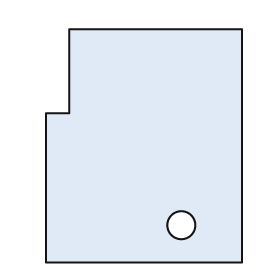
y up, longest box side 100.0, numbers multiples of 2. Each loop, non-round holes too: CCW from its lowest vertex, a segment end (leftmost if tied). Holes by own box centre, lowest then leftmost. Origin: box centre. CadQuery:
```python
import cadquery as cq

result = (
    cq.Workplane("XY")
    .moveTo(-42.0, -50.0)
    .lineTo(42.0, -50.0)
    .lineTo(42.0, 50.0)
    .lineTo(-32.0, 50.0)
    .lineTo(-32.0, 14.0)
    .lineTo(-42.0, 14.0)
    .close()
    .moveTo(16.0, -34.0)
    .circle(6.0)
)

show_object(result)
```